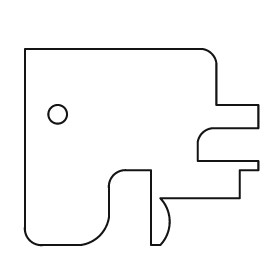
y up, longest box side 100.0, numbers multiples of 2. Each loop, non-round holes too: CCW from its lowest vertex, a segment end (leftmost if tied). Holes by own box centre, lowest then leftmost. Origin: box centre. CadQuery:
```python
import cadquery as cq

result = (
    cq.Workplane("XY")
    .moveTo(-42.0, -42.0)
    .lineTo(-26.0, -42.0)
    .threePointArc((-18.0, -38.0), (-14.0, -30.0))
    .lineTo(-14.0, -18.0)
    .threePointArc((-12.0, -12.0), (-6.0, -10.0))
    .lineTo(4.0, -10.0)
    .lineTo(4.0, -42.0)
    .lineTo(8.0, -42.0)
    .threePointArc((12.0, -32.0), (8.0, -22.0))
    .lineTo(42.0, -22.0)
    .lineTo(42.0, -10.0)
    .lineTo(50.0, -10.0)
    .lineTo(50.0, -6.0)
    .lineTo(24.0, -6.0)
    .lineTo(24.0, 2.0)
    .threePointArc((26.0, 6.0), (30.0, 8.0))
    .lineTo(50.0, 8.0)
    .lineTo(50.0, 18.0)
    .lineTo(32.0, 18.0)
    .lineTo(32.0, 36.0)
    .threePointArc((30.0, 40.0), (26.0, 42.0))
    .lineTo(-50.0, 42.0)
    .lineTo(-50.0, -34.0)
    .threePointArc((-48.0, -40.0), (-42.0, -42.0))
    .close()
    .moveTo(-36.0, 14.0)
    .circle(4.0)
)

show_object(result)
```